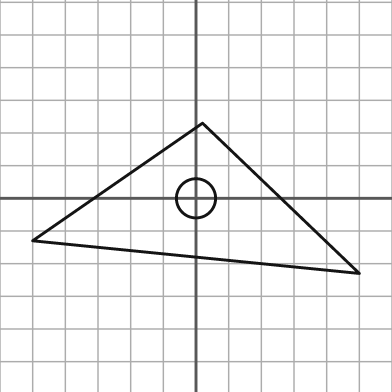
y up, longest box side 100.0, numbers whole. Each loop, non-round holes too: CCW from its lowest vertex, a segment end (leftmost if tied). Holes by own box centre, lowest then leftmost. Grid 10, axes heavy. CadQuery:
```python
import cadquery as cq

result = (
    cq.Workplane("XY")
    .moveTo(50.0, -23.0)
    .lineTo(2.0, 23.0)
    .lineTo(-50.0, -13.0)
    .close()
    .moveTo(0.0, 0.0)
    .circle(6.0)
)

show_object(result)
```